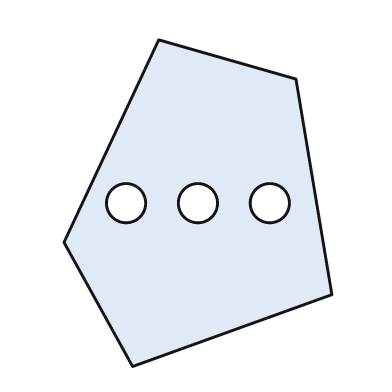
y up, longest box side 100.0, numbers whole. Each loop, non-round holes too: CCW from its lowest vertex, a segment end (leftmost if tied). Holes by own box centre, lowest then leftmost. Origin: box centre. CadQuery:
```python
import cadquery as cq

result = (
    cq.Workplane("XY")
    .moveTo(-20.0, -50.0)
    .lineTo(41.0, -28.0)
    .lineTo(30.0, 38.0)
    .lineTo(-12.0, 50.0)
    .lineTo(-41.0, -12.0)
    .close()
    .moveTo(-22.0, 0.0)
    .circle(6.0)
    .moveTo(0.0, 0.0)
    .circle(6.0)
    .moveTo(22.0, 0.0)
    .circle(6.0)
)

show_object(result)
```